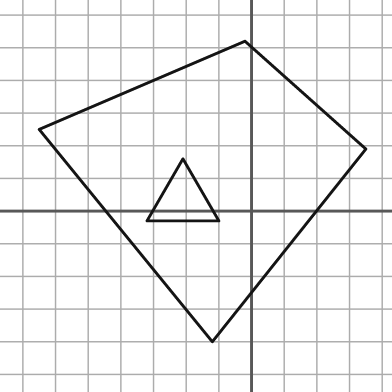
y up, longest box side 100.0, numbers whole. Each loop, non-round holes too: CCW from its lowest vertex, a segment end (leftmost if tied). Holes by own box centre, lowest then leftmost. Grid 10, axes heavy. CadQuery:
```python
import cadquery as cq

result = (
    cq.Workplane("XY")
    .moveTo(-12.0, -40.0)
    .lineTo(35.0, 19.0)
    .lineTo(-2.0, 52.0)
    .lineTo(-65.0, 25.0)
    .close()
    .moveTo(-32.0, -3.0)
    .lineTo(-10.0, -3.0)
    .lineTo(-21.0, 16.0)
    .close()
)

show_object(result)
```